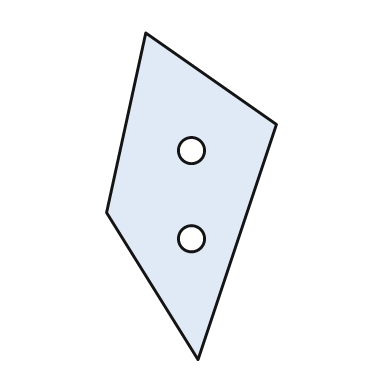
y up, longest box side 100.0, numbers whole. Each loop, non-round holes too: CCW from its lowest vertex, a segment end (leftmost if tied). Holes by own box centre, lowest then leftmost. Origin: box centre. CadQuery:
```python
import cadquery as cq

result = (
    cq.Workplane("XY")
    .moveTo(2.0, -50.0)
    .lineTo(26.0, 22.0)
    .lineTo(-14.0, 50.0)
    .lineTo(-26.0, -5.0)
    .close()
    .moveTo(0.0, -13.0)
    .circle(4.0)
    .moveTo(0.0, 14.0)
    .circle(4.0)
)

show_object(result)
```